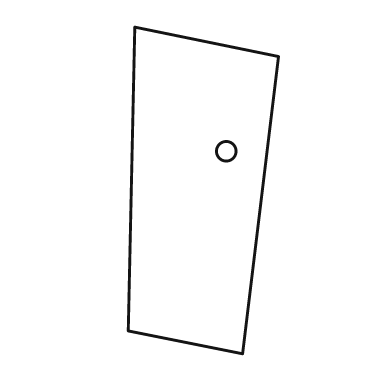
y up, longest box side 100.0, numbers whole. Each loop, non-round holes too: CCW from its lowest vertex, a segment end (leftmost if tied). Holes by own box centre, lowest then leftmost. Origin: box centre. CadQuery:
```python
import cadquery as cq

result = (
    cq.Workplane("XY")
    .moveTo(12.0, -50.0)
    .lineTo(23.0, 41.0)
    .lineTo(-21.0, 50.0)
    .lineTo(-23.0, -43.0)
    .close()
    .moveTo(7.0, 12.0)
    .circle(3.0)
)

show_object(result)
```